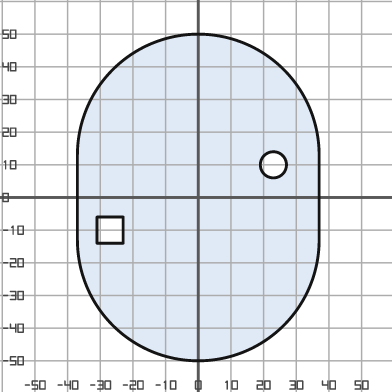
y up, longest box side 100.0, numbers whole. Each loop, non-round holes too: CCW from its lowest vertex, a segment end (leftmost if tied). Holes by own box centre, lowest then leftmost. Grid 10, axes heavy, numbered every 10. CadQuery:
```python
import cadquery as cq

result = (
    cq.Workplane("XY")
    .moveTo(-37.0, -13.0)
    .threePointArc((0.0, -50.0), (37.0, -13.0))
    .lineTo(37.0, 13.0)
    .threePointArc((0.0, 50.0), (-37.0, 13.0))
    .close()
    .moveTo(-31.0, -14.0)
    .lineTo(-23.0, -14.0)
    .lineTo(-23.0, -6.0)
    .lineTo(-31.0, -6.0)
    .close()
    .moveTo(23.0, 10.0)
    .circle(4.0)
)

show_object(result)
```